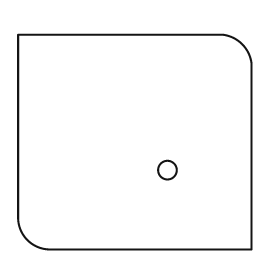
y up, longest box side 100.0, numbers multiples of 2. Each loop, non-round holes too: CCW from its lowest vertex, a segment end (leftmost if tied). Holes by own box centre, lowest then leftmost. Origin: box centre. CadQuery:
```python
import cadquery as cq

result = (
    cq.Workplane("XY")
    .moveTo(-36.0, -46.0)
    .lineTo(50.0, -46.0)
    .lineTo(50.0, 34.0)
    .threePointArc((46.0, 42.0), (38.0, 46.0))
    .lineTo(-50.0, 46.0)
    .lineTo(-50.0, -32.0)
    .threePointArc((-46.0, -42.0), (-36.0, -46.0))
    .close()
    .moveTo(14.0, -12.0)
    .circle(4.0)
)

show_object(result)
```